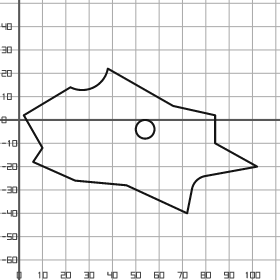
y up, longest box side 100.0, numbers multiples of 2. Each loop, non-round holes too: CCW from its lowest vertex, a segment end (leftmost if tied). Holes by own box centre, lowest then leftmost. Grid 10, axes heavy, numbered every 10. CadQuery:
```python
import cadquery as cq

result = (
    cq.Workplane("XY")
    .moveTo(72.0, -40.0)
    .lineTo(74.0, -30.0)
    .threePointArc((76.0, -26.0), (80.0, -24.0))
    .lineTo(102.0, -20.0)
    .lineTo(84.0, -10.0)
    .lineTo(84.0, 2.0)
    .lineTo(66.0, 6.0)
    .lineTo(38.0, 22.0)
    .threePointArc((32.0, 14.0), (22.0, 14.0))
    .lineTo(2.0, 2.0)
    .lineTo(10.0, -12.0)
    .lineTo(6.0, -18.0)
    .lineTo(24.0, -26.0)
    .lineTo(46.0, -28.0)
    .close()
    .moveTo(54.0, -4.0)
    .circle(4.0)
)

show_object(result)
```